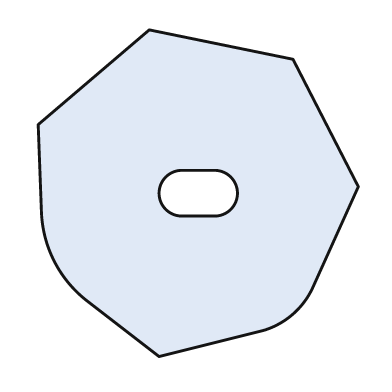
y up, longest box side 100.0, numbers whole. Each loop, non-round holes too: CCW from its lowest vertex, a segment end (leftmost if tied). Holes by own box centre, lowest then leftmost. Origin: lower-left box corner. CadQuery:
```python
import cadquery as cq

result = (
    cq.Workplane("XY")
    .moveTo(37.0, 0.0)
    .lineTo(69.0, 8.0)
    .threePointArc((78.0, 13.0), (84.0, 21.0))
    .lineTo(98.0, 52.0)
    .lineTo(78.0, 91.0)
    .lineTo(34.0, 100.0)
    .lineTo(0.0, 71.0)
    .lineTo(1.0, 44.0)
    .threePointArc((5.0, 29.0), (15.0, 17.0))
    .close()
    .moveTo(44.0, 43.0)
    .lineTo(54.0, 43.0)
    .threePointArc((61.0, 50.0), (54.0, 57.0))
    .lineTo(44.0, 57.0)
    .threePointArc((37.0, 50.0), (44.0, 43.0))
    .close()
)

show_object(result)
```